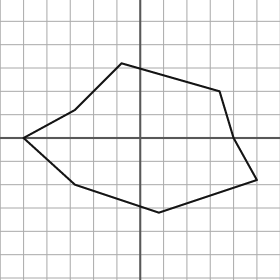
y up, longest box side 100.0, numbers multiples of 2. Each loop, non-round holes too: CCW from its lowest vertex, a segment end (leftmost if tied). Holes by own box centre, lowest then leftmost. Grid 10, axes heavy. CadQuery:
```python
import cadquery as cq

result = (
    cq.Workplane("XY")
    .moveTo(8.0, -32.0)
    .lineTo(50.0, -18.0)
    .lineTo(40.0, 0.0)
    .lineTo(34.0, 20.0)
    .lineTo(-8.0, 32.0)
    .lineTo(-28.0, 12.0)
    .lineTo(-50.0, 0.0)
    .lineTo(-28.0, -20.0)
    .close()
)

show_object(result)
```